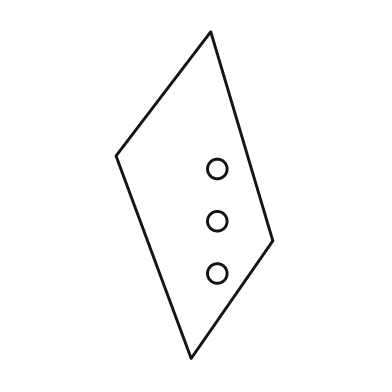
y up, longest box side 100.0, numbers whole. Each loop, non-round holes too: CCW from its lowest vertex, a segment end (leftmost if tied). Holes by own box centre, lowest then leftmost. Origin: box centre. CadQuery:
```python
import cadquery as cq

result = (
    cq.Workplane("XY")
    .moveTo(-1.0, -50.0)
    .lineTo(24.0, -14.0)
    .lineTo(5.0, 50.0)
    .lineTo(-24.0, 12.0)
    .close()
    .moveTo(7.0, -24.0)
    .circle(3.0)
    .moveTo(7.0, -8.0)
    .circle(3.0)
    .moveTo(7.0, 8.0)
    .circle(3.0)
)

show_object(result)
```